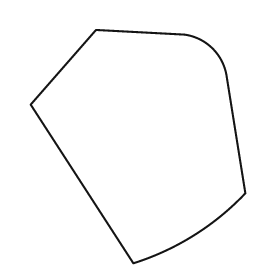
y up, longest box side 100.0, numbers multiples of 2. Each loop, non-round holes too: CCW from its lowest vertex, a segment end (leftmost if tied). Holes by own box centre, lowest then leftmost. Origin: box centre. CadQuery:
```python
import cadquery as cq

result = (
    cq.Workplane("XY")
    .moveTo(-2.0, -50.0)
    .threePointArc((24.0, -38.0), (46.0, -20.0))
    .lineTo(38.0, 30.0)
    .threePointArc((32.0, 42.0), (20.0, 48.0))
    .lineTo(-18.0, 50.0)
    .lineTo(-46.0, 18.0)
    .close()
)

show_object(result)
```